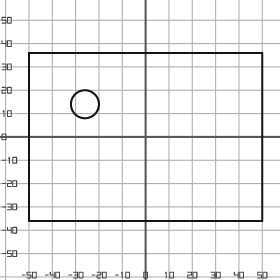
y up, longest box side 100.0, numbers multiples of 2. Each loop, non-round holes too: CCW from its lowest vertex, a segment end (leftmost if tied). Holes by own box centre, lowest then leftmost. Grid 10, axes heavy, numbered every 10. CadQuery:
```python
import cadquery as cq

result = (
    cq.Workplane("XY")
    .moveTo(-50.0, -36.0)
    .lineTo(50.0, -36.0)
    .lineTo(50.0, 36.0)
    .lineTo(-50.0, 36.0)
    .close()
    .moveTo(-26.0, 14.0)
    .circle(6.0)
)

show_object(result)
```